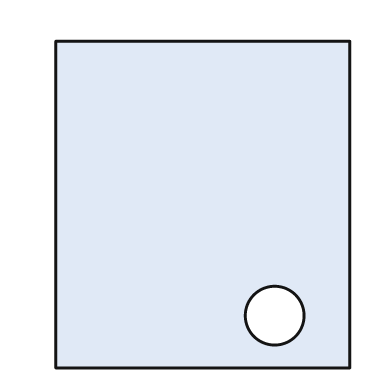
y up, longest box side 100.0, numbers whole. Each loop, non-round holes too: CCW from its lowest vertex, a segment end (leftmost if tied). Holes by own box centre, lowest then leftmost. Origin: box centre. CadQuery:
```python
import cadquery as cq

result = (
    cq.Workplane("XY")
    .moveTo(-45.0, -50.0)
    .lineTo(45.0, -50.0)
    .lineTo(45.0, 50.0)
    .lineTo(-45.0, 50.0)
    .close()
    .moveTo(22.0, -34.0)
    .circle(9.0)
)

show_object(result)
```